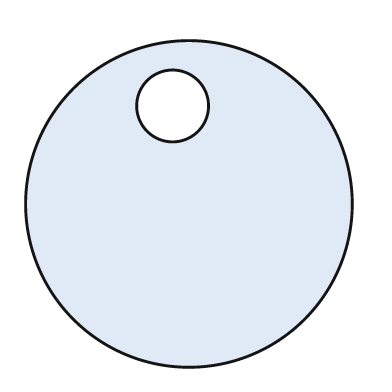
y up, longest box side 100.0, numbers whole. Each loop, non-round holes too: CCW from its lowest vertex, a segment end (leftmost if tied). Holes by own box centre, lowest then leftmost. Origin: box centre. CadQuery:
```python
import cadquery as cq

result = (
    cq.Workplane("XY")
    .moveTo(0.0, 0.0)
    .circle(50.0)
    .moveTo(-5.0, 30.0)
    .circle(11.0)
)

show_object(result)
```